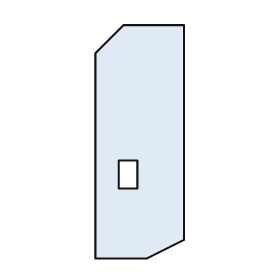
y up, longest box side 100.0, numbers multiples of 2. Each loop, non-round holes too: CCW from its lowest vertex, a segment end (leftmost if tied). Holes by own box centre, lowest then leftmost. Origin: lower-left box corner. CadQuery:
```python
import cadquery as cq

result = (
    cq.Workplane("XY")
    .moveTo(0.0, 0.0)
    .lineTo(22.0, 0.0)
    .lineTo(38.0, 8.0)
    .lineTo(38.0, 100.0)
    .lineTo(12.0, 100.0)
    .lineTo(0.0, 88.0)
    .close()
    .moveTo(10.0, 30.0)
    .lineTo(18.0, 30.0)
    .lineTo(18.0, 42.0)
    .lineTo(10.0, 42.0)
    .close()
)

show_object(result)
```